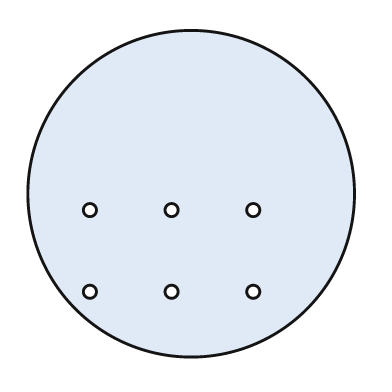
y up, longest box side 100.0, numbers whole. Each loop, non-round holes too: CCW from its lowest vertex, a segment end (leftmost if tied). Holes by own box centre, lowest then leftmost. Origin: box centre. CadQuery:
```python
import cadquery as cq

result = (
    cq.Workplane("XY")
    .moveTo(0.0, 0.0)
    .circle(50.0)
    .moveTo(-31.0, -30.0)
    .circle(2.0)
    .moveTo(-6.0, -30.0)
    .circle(2.0)
    .moveTo(19.0, -30.0)
    .circle(2.0)
    .moveTo(-31.0, -5.0)
    .circle(2.0)
    .moveTo(-6.0, -5.0)
    .circle(2.0)
    .moveTo(19.0, -5.0)
    .circle(2.0)
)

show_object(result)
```